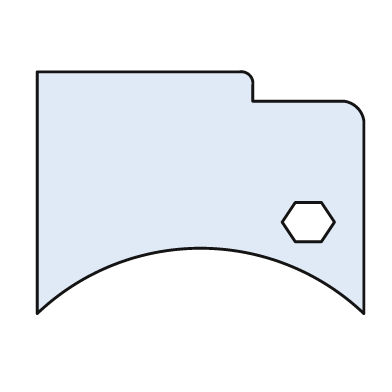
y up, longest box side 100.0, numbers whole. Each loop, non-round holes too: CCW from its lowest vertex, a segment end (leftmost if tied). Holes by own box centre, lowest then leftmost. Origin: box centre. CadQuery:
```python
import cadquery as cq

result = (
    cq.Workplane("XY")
    .moveTo(-50.0, -37.0)
    .threePointArc((0.0, -17.0), (50.0, -37.0))
    .lineTo(50.0, 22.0)
    .threePointArc((48.0, 26.0), (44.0, 28.0))
    .lineTo(16.0, 28.0)
    .lineTo(16.0, 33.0)
    .threePointArc((15.0, 36.0), (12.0, 37.0))
    .lineTo(-50.0, 37.0)
    .close()
    .moveTo(29.0, -15.0)
    .lineTo(37.0, -15.0)
    .lineTo(41.0, -9.0)
    .lineTo(37.0, -3.0)
    .lineTo(29.0, -3.0)
    .lineTo(25.0, -9.0)
    .close()
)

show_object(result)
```